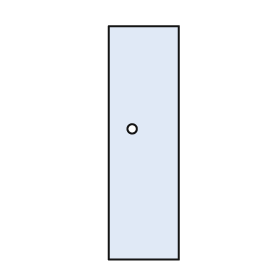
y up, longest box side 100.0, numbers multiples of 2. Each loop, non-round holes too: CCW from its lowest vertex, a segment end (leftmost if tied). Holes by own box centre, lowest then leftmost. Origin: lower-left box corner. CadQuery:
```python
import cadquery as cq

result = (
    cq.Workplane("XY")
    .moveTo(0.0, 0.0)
    .lineTo(30.0, 0.0)
    .lineTo(30.0, 100.0)
    .lineTo(0.0, 100.0)
    .close()
    .moveTo(10.0, 56.0)
    .circle(2.0)
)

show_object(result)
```